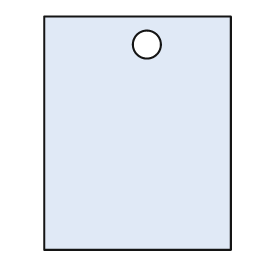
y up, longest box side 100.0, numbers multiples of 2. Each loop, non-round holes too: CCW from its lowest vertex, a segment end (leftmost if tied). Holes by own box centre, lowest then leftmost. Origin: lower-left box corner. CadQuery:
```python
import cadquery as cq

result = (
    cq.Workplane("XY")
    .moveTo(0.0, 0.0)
    .lineTo(80.0, 0.0)
    .lineTo(80.0, 100.0)
    .lineTo(0.0, 100.0)
    .close()
    .moveTo(44.0, 88.0)
    .circle(6.0)
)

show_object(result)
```